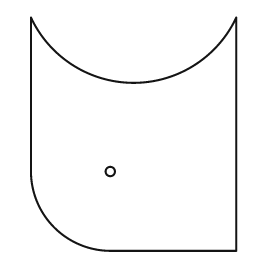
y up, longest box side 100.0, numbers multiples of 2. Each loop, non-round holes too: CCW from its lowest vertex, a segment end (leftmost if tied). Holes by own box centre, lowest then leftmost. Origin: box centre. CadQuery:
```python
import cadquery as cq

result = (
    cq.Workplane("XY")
    .moveTo(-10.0, -50.0)
    .lineTo(44.0, -50.0)
    .lineTo(44.0, 50.0)
    .threePointArc((0.0, 22.0), (-44.0, 50.0))
    .lineTo(-44.0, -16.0)
    .threePointArc((-34.0, -40.0), (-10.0, -50.0))
    .close()
    .moveTo(-10.0, -16.0)
    .circle(2.0)
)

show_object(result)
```